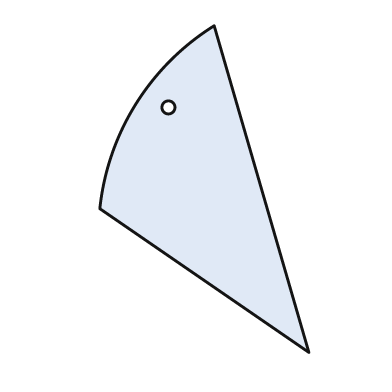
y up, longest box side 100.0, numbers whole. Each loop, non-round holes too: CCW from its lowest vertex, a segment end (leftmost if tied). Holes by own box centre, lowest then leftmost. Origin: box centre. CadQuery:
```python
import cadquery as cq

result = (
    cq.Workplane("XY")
    .moveTo(32.0, -50.0)
    .lineTo(3.0, 50.0)
    .threePointArc((-21.0, 26.0), (-32.0, -6.0))
    .close()
    .moveTo(-11.0, 25.0)
    .circle(2.0)
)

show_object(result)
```